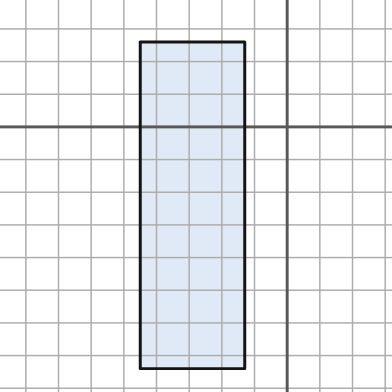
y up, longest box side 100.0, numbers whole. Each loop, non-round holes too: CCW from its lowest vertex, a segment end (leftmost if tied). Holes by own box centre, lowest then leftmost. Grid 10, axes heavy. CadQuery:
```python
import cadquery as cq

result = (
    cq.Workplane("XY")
    .moveTo(-45.0, -74.0)
    .lineTo(-13.0, -74.0)
    .lineTo(-13.0, 26.0)
    .lineTo(-45.0, 26.0)
    .close()
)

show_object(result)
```